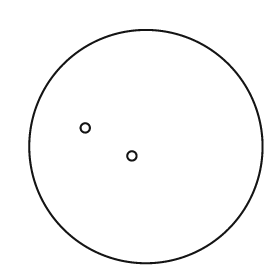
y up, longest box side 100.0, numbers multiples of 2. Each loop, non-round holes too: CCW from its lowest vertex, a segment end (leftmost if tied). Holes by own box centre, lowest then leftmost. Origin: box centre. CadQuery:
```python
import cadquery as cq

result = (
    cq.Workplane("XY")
    .moveTo(0.0, 0.0)
    .circle(50.0)
    .moveTo(-6.0, -4.0)
    .circle(2.0)
    .moveTo(-26.0, 8.0)
    .circle(2.0)
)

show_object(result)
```